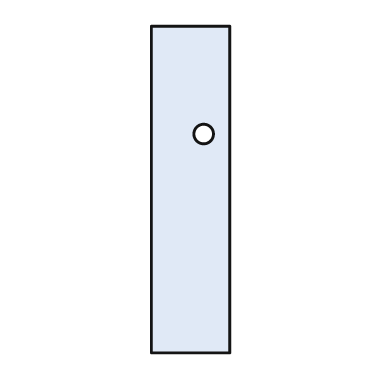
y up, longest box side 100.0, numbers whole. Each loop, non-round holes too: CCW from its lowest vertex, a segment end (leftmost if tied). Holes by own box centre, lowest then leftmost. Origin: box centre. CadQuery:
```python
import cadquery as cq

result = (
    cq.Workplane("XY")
    .moveTo(-12.0, -50.0)
    .lineTo(12.0, -50.0)
    .lineTo(12.0, 50.0)
    .lineTo(-12.0, 50.0)
    .close()
    .moveTo(4.0, 17.0)
    .circle(3.0)
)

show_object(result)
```